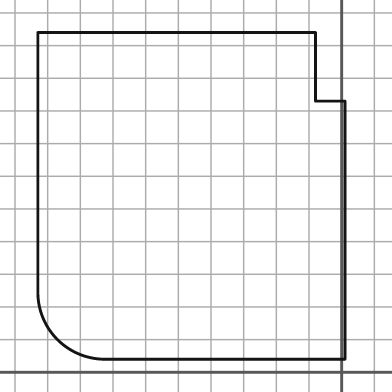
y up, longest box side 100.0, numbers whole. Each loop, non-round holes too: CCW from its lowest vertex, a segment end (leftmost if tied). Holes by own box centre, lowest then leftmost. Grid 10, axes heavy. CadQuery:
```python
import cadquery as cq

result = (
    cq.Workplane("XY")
    .moveTo(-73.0, 4.0)
    .lineTo(1.0, 4.0)
    .lineTo(1.0, 83.0)
    .lineTo(-8.0, 83.0)
    .lineTo(-8.0, 104.0)
    .lineTo(-93.0, 104.0)
    .lineTo(-93.0, 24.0)
    .threePointArc((-87.0, 10.0), (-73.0, 4.0))
    .close()
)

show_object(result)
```